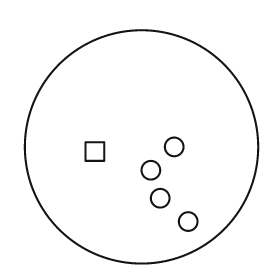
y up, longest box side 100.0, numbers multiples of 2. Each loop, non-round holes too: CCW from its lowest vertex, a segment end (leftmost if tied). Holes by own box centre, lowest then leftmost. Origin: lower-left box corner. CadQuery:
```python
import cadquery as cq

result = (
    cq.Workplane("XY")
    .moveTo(50.0, 50.0)
    .circle(50.0)
    .moveTo(70.0, 18.0)
    .circle(4.0)
    .moveTo(58.0, 28.0)
    .circle(4.0)
    .moveTo(54.0, 40.0)
    .circle(4.0)
    .moveTo(26.0, 44.0)
    .lineTo(34.0, 44.0)
    .lineTo(34.0, 52.0)
    .lineTo(26.0, 52.0)
    .close()
    .moveTo(64.0, 50.0)
    .circle(4.0)
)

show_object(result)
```